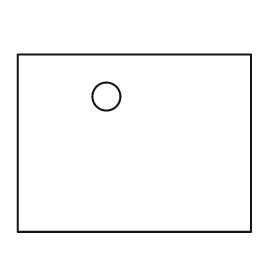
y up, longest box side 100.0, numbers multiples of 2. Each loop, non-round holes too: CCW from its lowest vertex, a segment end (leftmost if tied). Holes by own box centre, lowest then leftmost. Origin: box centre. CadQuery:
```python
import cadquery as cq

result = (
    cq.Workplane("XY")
    .moveTo(-50.0, -38.0)
    .lineTo(50.0, -38.0)
    .lineTo(50.0, 38.0)
    .lineTo(-50.0, 38.0)
    .close()
    .moveTo(-12.0, 20.0)
    .circle(6.0)
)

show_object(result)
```